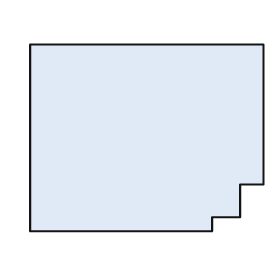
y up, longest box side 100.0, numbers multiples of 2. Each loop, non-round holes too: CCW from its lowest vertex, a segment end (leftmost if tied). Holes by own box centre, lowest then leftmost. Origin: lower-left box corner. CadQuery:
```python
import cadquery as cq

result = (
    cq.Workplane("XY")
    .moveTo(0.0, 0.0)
    .lineTo(78.0, 0.0)
    .lineTo(78.0, 6.0)
    .lineTo(90.0, 6.0)
    .lineTo(90.0, 20.0)
    .lineTo(100.0, 20.0)
    .lineTo(100.0, 80.0)
    .lineTo(0.0, 80.0)
    .close()
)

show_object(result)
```